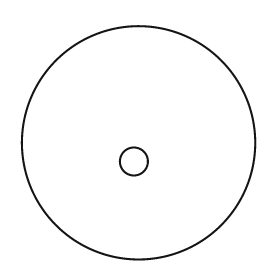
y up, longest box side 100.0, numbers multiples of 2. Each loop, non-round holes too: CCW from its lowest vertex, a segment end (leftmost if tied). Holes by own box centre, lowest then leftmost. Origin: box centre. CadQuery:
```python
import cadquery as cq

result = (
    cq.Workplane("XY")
    .moveTo(0.0, 0.0)
    .circle(50.0)
    .moveTo(-2.0, -8.0)
    .circle(6.0)
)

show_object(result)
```